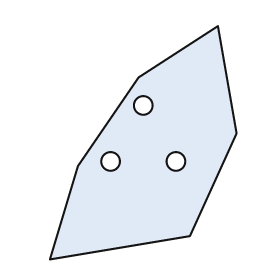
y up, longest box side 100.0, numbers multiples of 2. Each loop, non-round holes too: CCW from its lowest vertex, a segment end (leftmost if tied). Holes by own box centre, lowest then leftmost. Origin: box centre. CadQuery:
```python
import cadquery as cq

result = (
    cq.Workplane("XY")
    .moveTo(-40.0, -50.0)
    .lineTo(20.0, -40.0)
    .lineTo(40.0, 4.0)
    .lineTo(32.0, 50.0)
    .lineTo(-2.0, 28.0)
    .lineTo(-28.0, -10.0)
    .close()
    .moveTo(-14.0, -8.0)
    .circle(4.0)
    .moveTo(14.0, -8.0)
    .circle(4.0)
    .moveTo(0.0, 16.0)
    .circle(4.0)
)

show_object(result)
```